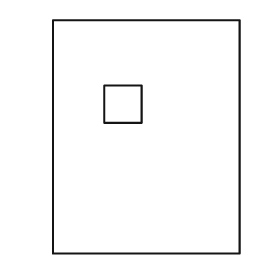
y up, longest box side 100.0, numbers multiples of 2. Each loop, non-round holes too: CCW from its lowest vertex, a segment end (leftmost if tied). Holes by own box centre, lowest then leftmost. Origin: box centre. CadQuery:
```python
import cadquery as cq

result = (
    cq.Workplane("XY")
    .moveTo(-40.0, -50.0)
    .lineTo(40.0, -50.0)
    .lineTo(40.0, 50.0)
    .lineTo(-40.0, 50.0)
    .close()
    .moveTo(-18.0, 6.0)
    .lineTo(-2.0, 6.0)
    .lineTo(-2.0, 22.0)
    .lineTo(-18.0, 22.0)
    .close()
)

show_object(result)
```